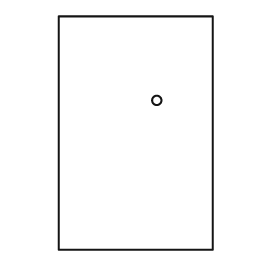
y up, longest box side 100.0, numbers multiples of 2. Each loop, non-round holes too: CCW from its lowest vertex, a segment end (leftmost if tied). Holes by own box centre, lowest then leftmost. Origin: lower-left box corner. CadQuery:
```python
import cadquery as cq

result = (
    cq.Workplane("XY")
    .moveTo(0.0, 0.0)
    .lineTo(66.0, 0.0)
    .lineTo(66.0, 100.0)
    .lineTo(0.0, 100.0)
    .close()
    .moveTo(42.0, 64.0)
    .circle(2.0)
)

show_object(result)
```